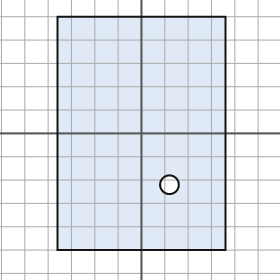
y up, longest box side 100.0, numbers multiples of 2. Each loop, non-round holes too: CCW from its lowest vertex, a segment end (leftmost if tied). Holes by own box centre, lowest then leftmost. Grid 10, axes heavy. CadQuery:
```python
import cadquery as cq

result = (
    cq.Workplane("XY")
    .moveTo(-36.0, -50.0)
    .lineTo(36.0, -50.0)
    .lineTo(36.0, 50.0)
    .lineTo(-36.0, 50.0)
    .close()
    .moveTo(12.0, -22.0)
    .circle(4.0)
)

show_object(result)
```